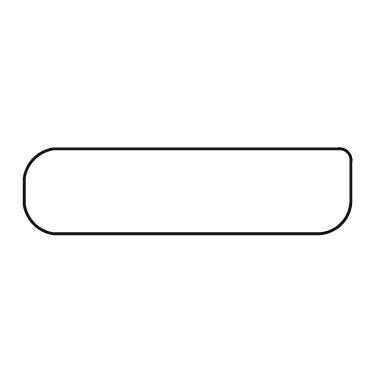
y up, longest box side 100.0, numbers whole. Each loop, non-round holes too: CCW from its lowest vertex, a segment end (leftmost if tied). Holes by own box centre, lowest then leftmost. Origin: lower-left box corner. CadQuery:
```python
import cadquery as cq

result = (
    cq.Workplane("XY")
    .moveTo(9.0, 0.0)
    .lineTo(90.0, 0.0)
    .threePointArc((97.0, 3.0), (100.0, 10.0))
    .lineTo(100.0, 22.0)
    .threePointArc((99.0, 25.0), (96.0, 26.0))
    .lineTo(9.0, 26.0)
    .threePointArc((3.0, 23.0), (0.0, 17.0))
    .lineTo(0.0, 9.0)
    .threePointArc((3.0, 3.0), (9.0, 0.0))
    .close()
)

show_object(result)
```